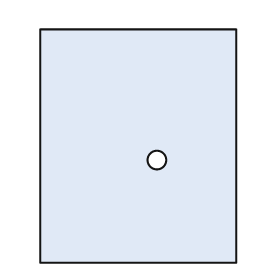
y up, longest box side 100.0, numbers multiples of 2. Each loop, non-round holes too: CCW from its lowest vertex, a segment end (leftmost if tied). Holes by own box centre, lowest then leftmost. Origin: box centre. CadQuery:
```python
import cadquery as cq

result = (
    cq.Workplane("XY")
    .moveTo(-42.0, -50.0)
    .lineTo(42.0, -50.0)
    .lineTo(42.0, 50.0)
    .lineTo(-42.0, 50.0)
    .close()
    .moveTo(8.0, -6.0)
    .circle(4.0)
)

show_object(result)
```